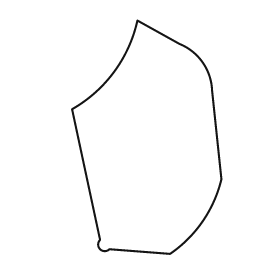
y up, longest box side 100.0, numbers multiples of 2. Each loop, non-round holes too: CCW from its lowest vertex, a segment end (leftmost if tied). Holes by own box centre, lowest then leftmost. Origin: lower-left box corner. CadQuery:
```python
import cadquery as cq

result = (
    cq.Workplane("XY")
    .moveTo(42.0, 0.0)
    .threePointArc((56.0, 14.0), (64.0, 32.0))
    .lineTo(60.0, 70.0)
    .threePointArc((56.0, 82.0), (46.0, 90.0))
    .lineTo(28.0, 100.0)
    .threePointArc((18.0, 78.0), (0.0, 62.0))
    .lineTo(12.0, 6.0)
    .threePointArc((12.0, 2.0), (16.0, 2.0))
    .close()
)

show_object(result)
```